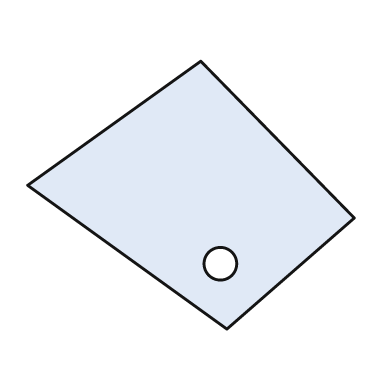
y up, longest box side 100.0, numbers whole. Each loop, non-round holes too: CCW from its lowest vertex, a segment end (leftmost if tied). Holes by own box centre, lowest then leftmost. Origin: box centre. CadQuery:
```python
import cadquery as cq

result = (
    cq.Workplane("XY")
    .moveTo(11.0, -41.0)
    .lineTo(50.0, -7.0)
    .lineTo(3.0, 41.0)
    .lineTo(-50.0, 3.0)
    .close()
    .moveTo(9.0, -21.0)
    .circle(5.0)
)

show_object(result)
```